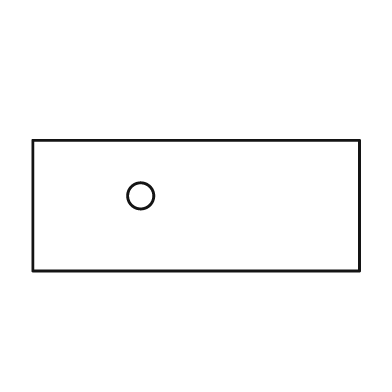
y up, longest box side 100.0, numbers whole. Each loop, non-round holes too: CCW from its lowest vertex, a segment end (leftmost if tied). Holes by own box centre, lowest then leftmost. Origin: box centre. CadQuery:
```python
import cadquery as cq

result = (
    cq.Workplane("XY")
    .moveTo(-50.0, -20.0)
    .lineTo(50.0, -20.0)
    .lineTo(50.0, 20.0)
    .lineTo(-50.0, 20.0)
    .close()
    .moveTo(-17.0, 3.0)
    .circle(4.0)
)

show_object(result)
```